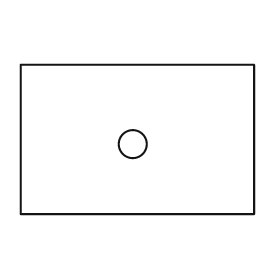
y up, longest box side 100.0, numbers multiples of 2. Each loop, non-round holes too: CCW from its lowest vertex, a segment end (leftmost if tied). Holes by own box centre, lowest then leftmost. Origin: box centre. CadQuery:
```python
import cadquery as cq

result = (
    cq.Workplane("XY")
    .moveTo(-50.0, -32.0)
    .lineTo(50.0, -32.0)
    .lineTo(50.0, 32.0)
    .lineTo(-50.0, 32.0)
    .close()
    .moveTo(-2.0, -2.0)
    .circle(6.0)
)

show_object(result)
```